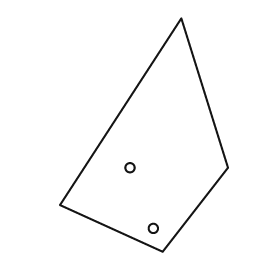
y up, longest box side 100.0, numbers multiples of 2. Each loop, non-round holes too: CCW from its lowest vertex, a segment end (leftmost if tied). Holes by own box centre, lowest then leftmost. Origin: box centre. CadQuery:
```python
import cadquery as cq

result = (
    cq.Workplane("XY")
    .moveTo(8.0, -50.0)
    .lineTo(36.0, -14.0)
    .lineTo(16.0, 50.0)
    .lineTo(-36.0, -30.0)
    .close()
    .moveTo(4.0, -40.0)
    .circle(2.0)
    .moveTo(-6.0, -14.0)
    .circle(2.0)
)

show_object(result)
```